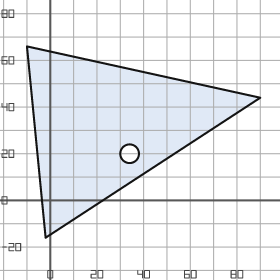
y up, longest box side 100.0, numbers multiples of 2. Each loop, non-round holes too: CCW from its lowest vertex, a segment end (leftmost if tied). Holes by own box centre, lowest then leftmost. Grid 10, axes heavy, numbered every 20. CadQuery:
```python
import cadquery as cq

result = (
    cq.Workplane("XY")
    .moveTo(-2.0, -16.0)
    .lineTo(90.0, 44.0)
    .lineTo(-10.0, 66.0)
    .close()
    .moveTo(34.0, 20.0)
    .circle(4.0)
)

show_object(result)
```